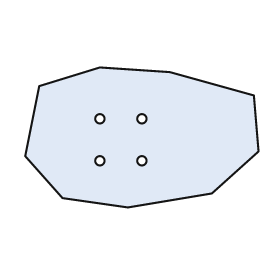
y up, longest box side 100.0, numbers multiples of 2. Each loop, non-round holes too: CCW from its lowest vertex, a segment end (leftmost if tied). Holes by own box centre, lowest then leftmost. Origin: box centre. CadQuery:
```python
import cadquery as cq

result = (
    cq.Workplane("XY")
    .moveTo(-6.0, -30.0)
    .lineTo(30.0, -24.0)
    .lineTo(50.0, -6.0)
    .lineTo(48.0, 18.0)
    .lineTo(12.0, 28.0)
    .lineTo(-18.0, 30.0)
    .lineTo(-44.0, 22.0)
    .lineTo(-50.0, -8.0)
    .lineTo(-34.0, -26.0)
    .close()
    .moveTo(-18.0, -10.0)
    .circle(2.0)
    .moveTo(0.0, -10.0)
    .circle(2.0)
    .moveTo(-18.0, 8.0)
    .circle(2.0)
    .moveTo(0.0, 8.0)
    .circle(2.0)
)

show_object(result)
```